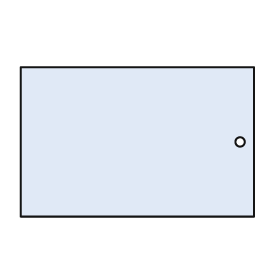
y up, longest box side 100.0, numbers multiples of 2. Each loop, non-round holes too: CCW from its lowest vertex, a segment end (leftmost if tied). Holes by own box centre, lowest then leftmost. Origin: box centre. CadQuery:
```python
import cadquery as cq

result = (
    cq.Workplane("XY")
    .moveTo(-50.0, -32.0)
    .lineTo(50.0, -32.0)
    .lineTo(50.0, 32.0)
    .lineTo(-50.0, 32.0)
    .close()
    .moveTo(44.0, 0.0)
    .circle(2.0)
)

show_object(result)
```